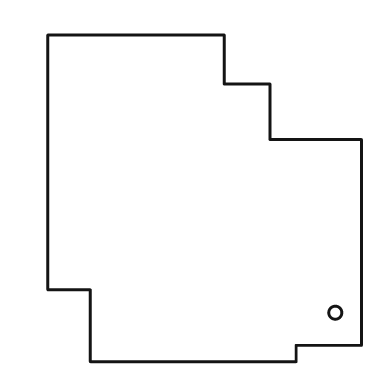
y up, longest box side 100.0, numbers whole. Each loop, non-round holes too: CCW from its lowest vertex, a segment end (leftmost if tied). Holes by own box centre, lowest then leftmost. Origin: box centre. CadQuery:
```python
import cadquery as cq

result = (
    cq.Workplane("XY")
    .moveTo(-35.0, -50.0)
    .lineTo(28.0, -50.0)
    .lineTo(28.0, -45.0)
    .lineTo(48.0, -45.0)
    .lineTo(48.0, 18.0)
    .lineTo(20.0, 18.0)
    .lineTo(20.0, 35.0)
    .lineTo(6.0, 35.0)
    .lineTo(6.0, 50.0)
    .lineTo(-48.0, 50.0)
    .lineTo(-48.0, -28.0)
    .lineTo(-35.0, -28.0)
    .close()
    .moveTo(40.0, -35.0)
    .circle(2.0)
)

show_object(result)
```